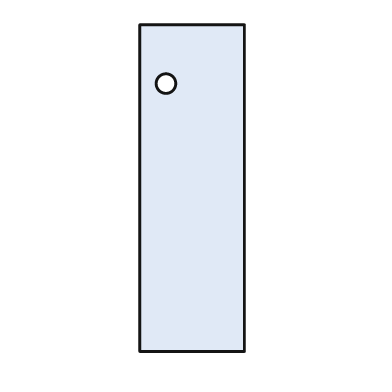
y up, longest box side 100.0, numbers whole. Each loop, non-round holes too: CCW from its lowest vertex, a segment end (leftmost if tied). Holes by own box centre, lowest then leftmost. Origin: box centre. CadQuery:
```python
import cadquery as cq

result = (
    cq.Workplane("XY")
    .moveTo(-16.0, -50.0)
    .lineTo(16.0, -50.0)
    .lineTo(16.0, 50.0)
    .lineTo(-16.0, 50.0)
    .close()
    .moveTo(-8.0, 32.0)
    .circle(3.0)
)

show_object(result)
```